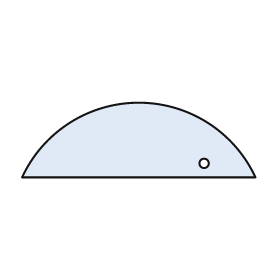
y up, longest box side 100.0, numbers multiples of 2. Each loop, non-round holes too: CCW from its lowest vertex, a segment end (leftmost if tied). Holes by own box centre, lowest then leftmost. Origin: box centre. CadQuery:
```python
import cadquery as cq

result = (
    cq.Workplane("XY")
    .moveTo(-50.0, -16.0)
    .lineTo(50.0, -16.0)
    .threePointArc((0.0, 16.0), (-50.0, -16.0))
    .close()
    .moveTo(28.0, -10.0)
    .circle(2.0)
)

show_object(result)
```